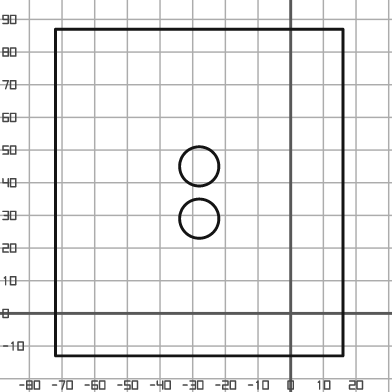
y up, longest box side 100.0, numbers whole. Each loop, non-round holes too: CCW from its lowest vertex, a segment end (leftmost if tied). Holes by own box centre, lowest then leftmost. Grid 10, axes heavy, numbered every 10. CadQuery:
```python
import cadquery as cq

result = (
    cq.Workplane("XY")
    .moveTo(-72.0, -13.0)
    .lineTo(16.0, -13.0)
    .lineTo(16.0, 87.0)
    .lineTo(-72.0, 87.0)
    .close()
    .moveTo(-28.0, 29.0)
    .circle(6.0)
    .moveTo(-28.0, 45.0)
    .circle(6.0)
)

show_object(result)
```